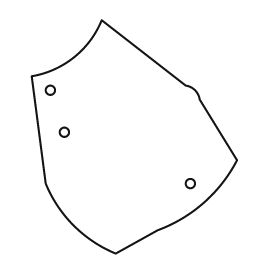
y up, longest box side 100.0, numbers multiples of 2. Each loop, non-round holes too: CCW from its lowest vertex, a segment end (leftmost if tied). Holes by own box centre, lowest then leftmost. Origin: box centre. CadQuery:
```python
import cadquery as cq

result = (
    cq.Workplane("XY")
    .moveTo(-8.0, -50.0)
    .lineTo(10.0, -40.0)
    .threePointArc((30.0, -28.0), (44.0, -10.0))
    .lineTo(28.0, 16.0)
    .threePointArc((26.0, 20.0), (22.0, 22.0))
    .lineTo(-14.0, 50.0)
    .threePointArc((-26.0, 34.0), (-44.0, 26.0))
    .lineTo(-38.0, -20.0)
    .threePointArc((-26.0, -38.0), (-8.0, -50.0))
    .close()
    .moveTo(24.0, -20.0)
    .circle(2.0)
    .moveTo(-30.0, 2.0)
    .circle(2.0)
    .moveTo(-36.0, 20.0)
    .circle(2.0)
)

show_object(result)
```